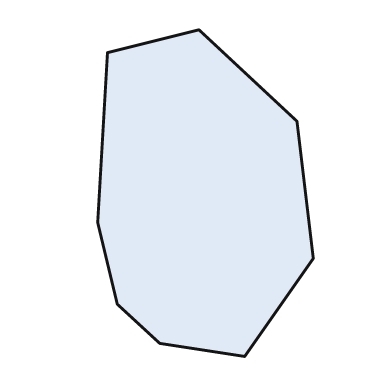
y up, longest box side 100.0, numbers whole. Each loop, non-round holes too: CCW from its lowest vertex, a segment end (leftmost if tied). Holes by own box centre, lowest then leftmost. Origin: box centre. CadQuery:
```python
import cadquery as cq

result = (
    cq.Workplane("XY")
    .moveTo(12.0, -50.0)
    .lineTo(33.0, -20.0)
    .lineTo(28.0, 22.0)
    .lineTo(-2.0, 50.0)
    .lineTo(-30.0, 43.0)
    .lineTo(-33.0, -9.0)
    .lineTo(-27.0, -34.0)
    .lineTo(-14.0, -46.0)
    .close()
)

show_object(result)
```